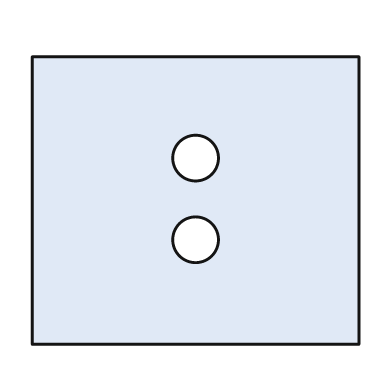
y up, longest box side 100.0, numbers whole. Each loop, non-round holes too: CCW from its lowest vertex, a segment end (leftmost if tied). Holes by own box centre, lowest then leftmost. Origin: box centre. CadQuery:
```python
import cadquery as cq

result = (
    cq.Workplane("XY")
    .moveTo(-50.0, -44.0)
    .lineTo(50.0, -44.0)
    .lineTo(50.0, 44.0)
    .lineTo(-50.0, 44.0)
    .close()
    .moveTo(0.0, -12.0)
    .circle(7.0)
    .moveTo(0.0, 13.0)
    .circle(7.0)
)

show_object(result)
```